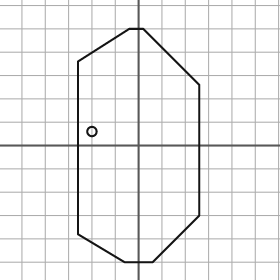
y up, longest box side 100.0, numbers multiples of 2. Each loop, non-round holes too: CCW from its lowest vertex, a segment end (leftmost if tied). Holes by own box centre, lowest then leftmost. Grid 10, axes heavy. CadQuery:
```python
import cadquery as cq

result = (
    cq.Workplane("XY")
    .moveTo(-6.0, -50.0)
    .lineTo(6.0, -50.0)
    .lineTo(26.0, -30.0)
    .lineTo(26.0, 26.0)
    .lineTo(2.0, 50.0)
    .lineTo(-4.0, 50.0)
    .lineTo(-26.0, 36.0)
    .lineTo(-26.0, -38.0)
    .close()
    .moveTo(-20.0, 6.0)
    .circle(2.0)
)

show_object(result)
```